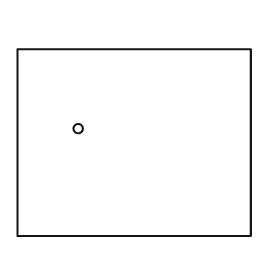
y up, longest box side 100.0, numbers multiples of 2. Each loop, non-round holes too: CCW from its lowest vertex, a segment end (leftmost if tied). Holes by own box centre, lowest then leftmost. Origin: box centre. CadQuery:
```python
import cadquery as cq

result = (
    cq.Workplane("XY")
    .moveTo(-50.0, -40.0)
    .lineTo(50.0, -40.0)
    .lineTo(50.0, 40.0)
    .lineTo(-50.0, 40.0)
    .close()
    .moveTo(-24.0, 6.0)
    .circle(2.0)
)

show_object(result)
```